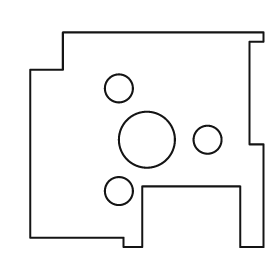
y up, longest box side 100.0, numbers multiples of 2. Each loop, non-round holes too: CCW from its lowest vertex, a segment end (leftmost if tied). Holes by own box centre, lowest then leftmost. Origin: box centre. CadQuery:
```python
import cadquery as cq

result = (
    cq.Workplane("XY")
    .moveTo(-10.0, -46.0)
    .lineTo(-2.0, -46.0)
    .lineTo(-2.0, -20.0)
    .lineTo(40.0, -20.0)
    .lineTo(40.0, -46.0)
    .lineTo(50.0, -46.0)
    .lineTo(50.0, -2.0)
    .lineTo(44.0, -2.0)
    .lineTo(44.0, 42.0)
    .lineTo(50.0, 42.0)
    .lineTo(50.0, 46.0)
    .lineTo(-36.0, 46.0)
    .lineTo(-36.0, 30.0)
    .lineTo(-50.0, 30.0)
    .lineTo(-50.0, -42.0)
    .lineTo(-10.0, -42.0)
    .close()
    .moveTo(-12.0, -22.0)
    .circle(6.0)
    .moveTo(0.0, 0.0)
    .circle(12.0)
    .moveTo(26.0, 0.0)
    .circle(6.0)
    .moveTo(-12.0, 22.0)
    .circle(6.0)
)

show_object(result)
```